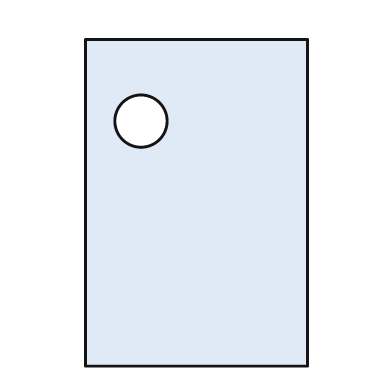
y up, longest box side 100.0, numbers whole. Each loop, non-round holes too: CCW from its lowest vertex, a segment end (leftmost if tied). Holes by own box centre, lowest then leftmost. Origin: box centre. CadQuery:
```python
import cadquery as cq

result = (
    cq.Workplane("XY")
    .moveTo(-34.0, -50.0)
    .lineTo(34.0, -50.0)
    .lineTo(34.0, 50.0)
    .lineTo(-34.0, 50.0)
    .close()
    .moveTo(-17.0, 25.0)
    .circle(8.0)
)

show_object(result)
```